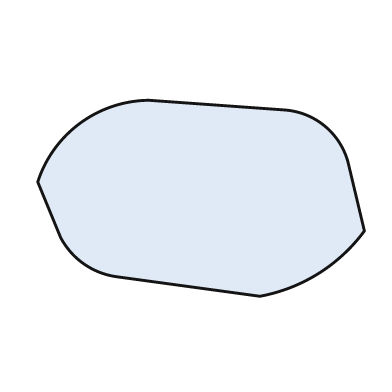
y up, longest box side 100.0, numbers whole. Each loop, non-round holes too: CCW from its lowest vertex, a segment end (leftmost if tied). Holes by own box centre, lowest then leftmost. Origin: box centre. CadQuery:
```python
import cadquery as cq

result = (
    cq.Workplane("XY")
    .moveTo(18.0, -30.0)
    .threePointArc((36.0, -23.0), (50.0, -10.0))
    .lineTo(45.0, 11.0)
    .threePointArc((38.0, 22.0), (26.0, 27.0))
    .lineTo(-16.0, 30.0)
    .threePointArc((-37.0, 23.0), (-50.0, 5.0))
    .lineTo(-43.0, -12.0)
    .threePointArc((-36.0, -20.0), (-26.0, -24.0))
    .close()
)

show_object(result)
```